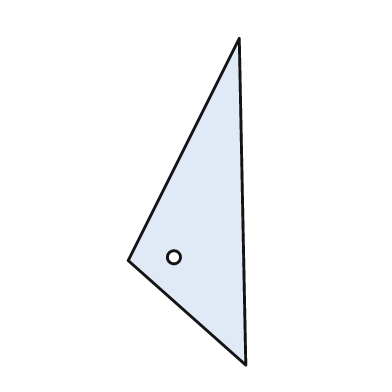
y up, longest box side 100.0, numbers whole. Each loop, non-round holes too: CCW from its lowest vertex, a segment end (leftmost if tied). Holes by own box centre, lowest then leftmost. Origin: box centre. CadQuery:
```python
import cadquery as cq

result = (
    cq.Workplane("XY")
    .moveTo(18.0, -50.0)
    .lineTo(16.0, 50.0)
    .lineTo(-18.0, -18.0)
    .close()
    .moveTo(-4.0, -17.0)
    .circle(2.0)
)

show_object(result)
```